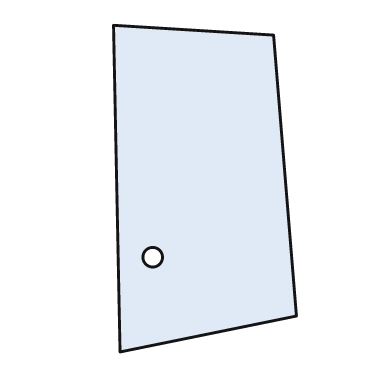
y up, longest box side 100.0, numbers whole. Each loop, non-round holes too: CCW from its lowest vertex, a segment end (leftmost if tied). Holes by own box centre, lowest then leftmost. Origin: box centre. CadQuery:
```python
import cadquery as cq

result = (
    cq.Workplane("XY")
    .moveTo(-26.0, -50.0)
    .lineTo(28.0, -39.0)
    .lineTo(21.0, 47.0)
    .lineTo(-28.0, 50.0)
    .close()
    .moveTo(-16.0, -21.0)
    .circle(3.0)
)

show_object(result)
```